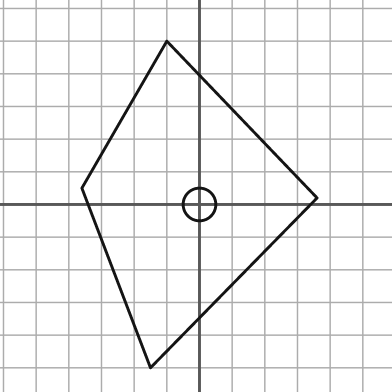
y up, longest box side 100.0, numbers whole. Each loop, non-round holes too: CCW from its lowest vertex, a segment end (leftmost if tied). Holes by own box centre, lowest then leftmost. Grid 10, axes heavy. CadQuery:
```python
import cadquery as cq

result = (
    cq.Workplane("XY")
    .moveTo(-15.0, -50.0)
    .lineTo(36.0, 2.0)
    .lineTo(-10.0, 50.0)
    .lineTo(-36.0, 5.0)
    .close()
    .moveTo(0.0, 0.0)
    .circle(5.0)
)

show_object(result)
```